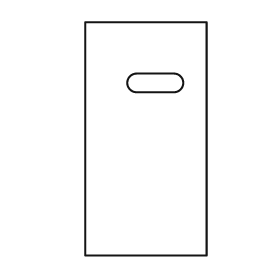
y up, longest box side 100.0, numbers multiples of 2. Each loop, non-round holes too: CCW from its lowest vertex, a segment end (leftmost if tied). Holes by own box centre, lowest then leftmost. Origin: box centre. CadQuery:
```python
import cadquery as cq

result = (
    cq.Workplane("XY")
    .moveTo(-26.0, -50.0)
    .lineTo(26.0, -50.0)
    .lineTo(26.0, 50.0)
    .lineTo(-26.0, 50.0)
    .close()
    .moveTo(-4.0, 20.0)
    .lineTo(12.0, 20.0)
    .threePointArc((16.0, 24.0), (12.0, 28.0))
    .lineTo(-4.0, 28.0)
    .threePointArc((-8.0, 24.0), (-4.0, 20.0))
    .close()
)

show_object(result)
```